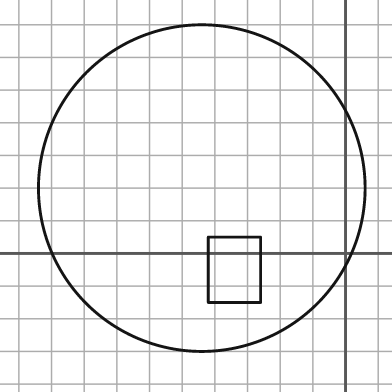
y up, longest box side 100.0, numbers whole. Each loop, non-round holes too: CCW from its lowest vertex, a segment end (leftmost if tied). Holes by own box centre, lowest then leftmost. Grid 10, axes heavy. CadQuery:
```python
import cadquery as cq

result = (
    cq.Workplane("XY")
    .moveTo(-44.0, 20.0)
    .circle(50.0)
    .moveTo(-42.0, -15.0)
    .lineTo(-26.0, -15.0)
    .lineTo(-26.0, 5.0)
    .lineTo(-42.0, 5.0)
    .close()
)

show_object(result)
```